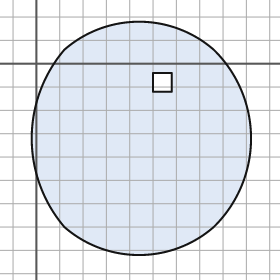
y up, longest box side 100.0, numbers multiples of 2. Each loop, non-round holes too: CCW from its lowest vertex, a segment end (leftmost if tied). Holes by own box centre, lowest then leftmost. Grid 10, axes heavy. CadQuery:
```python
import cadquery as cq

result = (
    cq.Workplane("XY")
    .moveTo(12.0, -70.0)
    .threePointArc((44.0, -82.0), (76.0, -70.0))
    .threePointArc((92.0, -32.0), (76.0, 6.0))
    .threePointArc((44.0, 18.0), (12.0, 6.0))
    .threePointArc((-2.0, -32.0), (12.0, -70.0))
    .close()
    .moveTo(50.0, -12.0)
    .lineTo(58.0, -12.0)
    .lineTo(58.0, -4.0)
    .lineTo(50.0, -4.0)
    .close()
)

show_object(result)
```